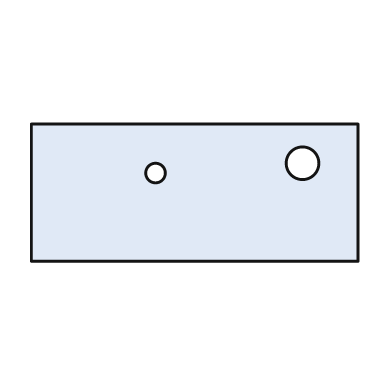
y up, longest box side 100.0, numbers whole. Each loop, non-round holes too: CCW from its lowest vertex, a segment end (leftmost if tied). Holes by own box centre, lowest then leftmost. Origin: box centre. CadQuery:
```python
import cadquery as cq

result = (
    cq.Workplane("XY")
    .moveTo(-50.0, -21.0)
    .lineTo(50.0, -21.0)
    .lineTo(50.0, 21.0)
    .lineTo(-50.0, 21.0)
    .close()
    .moveTo(-12.0, 6.0)
    .circle(3.0)
    .moveTo(33.0, 9.0)
    .circle(5.0)
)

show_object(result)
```